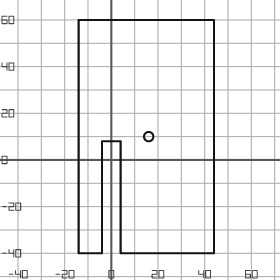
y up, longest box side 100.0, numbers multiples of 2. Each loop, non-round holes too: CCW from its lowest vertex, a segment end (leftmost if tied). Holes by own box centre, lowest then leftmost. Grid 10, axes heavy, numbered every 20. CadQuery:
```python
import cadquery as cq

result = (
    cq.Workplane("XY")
    .moveTo(-14.0, -40.0)
    .lineTo(-4.0, -40.0)
    .lineTo(-4.0, 8.0)
    .lineTo(4.0, 8.0)
    .lineTo(4.0, -40.0)
    .lineTo(44.0, -40.0)
    .lineTo(44.0, 60.0)
    .lineTo(-14.0, 60.0)
    .close()
    .moveTo(16.0, 10.0)
    .circle(2.0)
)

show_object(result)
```